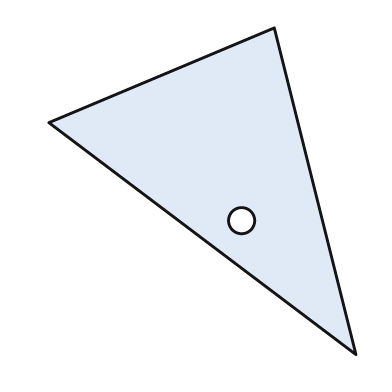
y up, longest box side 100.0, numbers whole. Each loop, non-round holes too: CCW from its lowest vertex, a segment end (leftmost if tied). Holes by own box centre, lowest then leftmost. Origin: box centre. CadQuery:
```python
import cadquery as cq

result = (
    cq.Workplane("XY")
    .moveTo(47.0, -50.0)
    .lineTo(22.0, 50.0)
    .lineTo(-47.0, 21.0)
    .close()
    .moveTo(12.0, -9.0)
    .circle(4.0)
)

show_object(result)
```